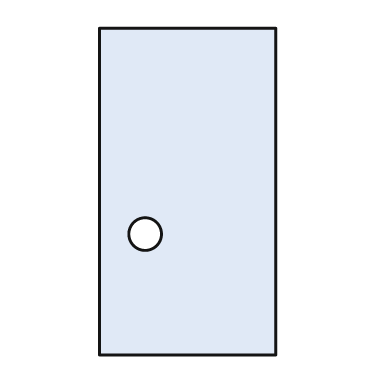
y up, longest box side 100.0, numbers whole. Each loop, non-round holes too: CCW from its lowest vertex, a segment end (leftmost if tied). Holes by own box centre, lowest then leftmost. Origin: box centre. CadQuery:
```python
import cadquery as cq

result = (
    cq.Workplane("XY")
    .moveTo(-27.0, -50.0)
    .lineTo(27.0, -50.0)
    .lineTo(27.0, 50.0)
    .lineTo(-27.0, 50.0)
    .close()
    .moveTo(-13.0, -13.0)
    .circle(5.0)
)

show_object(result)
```